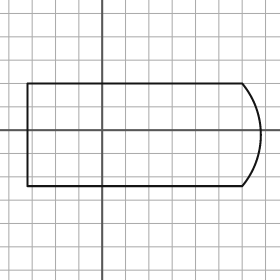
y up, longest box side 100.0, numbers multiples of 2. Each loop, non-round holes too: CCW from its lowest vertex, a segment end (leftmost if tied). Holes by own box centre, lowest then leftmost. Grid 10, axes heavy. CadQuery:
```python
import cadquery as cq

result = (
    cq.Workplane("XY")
    .moveTo(-32.0, -24.0)
    .lineTo(60.0, -24.0)
    .threePointArc((68.0, -2.0), (60.0, 20.0))
    .lineTo(-32.0, 20.0)
    .close()
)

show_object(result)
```